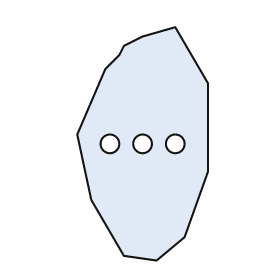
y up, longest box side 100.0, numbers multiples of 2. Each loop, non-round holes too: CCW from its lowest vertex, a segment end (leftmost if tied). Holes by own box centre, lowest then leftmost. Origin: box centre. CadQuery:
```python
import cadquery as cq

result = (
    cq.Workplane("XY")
    .moveTo(6.0, -50.0)
    .lineTo(18.0, -40.0)
    .lineTo(28.0, -12.0)
    .lineTo(28.0, 26.0)
    .lineTo(14.0, 50.0)
    .lineTo(0.0, 46.0)
    .lineTo(-8.0, 42.0)
    .lineTo(-10.0, 38.0)
    .lineTo(-16.0, 32.0)
    .lineTo(-28.0, 4.0)
    .lineTo(-22.0, -24.0)
    .lineTo(-8.0, -48.0)
    .close()
    .moveTo(-14.0, 0.0)
    .circle(4.0)
    .moveTo(0.0, 0.0)
    .circle(4.0)
    .moveTo(14.0, 0.0)
    .circle(4.0)
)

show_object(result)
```